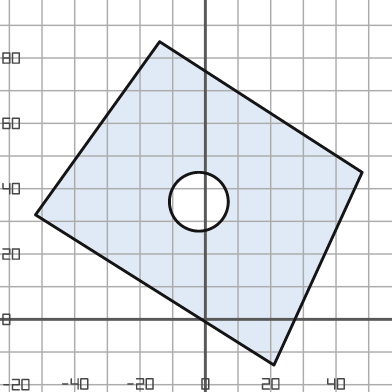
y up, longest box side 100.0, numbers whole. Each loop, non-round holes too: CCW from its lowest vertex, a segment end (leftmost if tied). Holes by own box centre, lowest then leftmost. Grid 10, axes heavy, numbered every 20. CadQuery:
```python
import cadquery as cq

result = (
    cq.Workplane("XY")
    .moveTo(21.0, -14.0)
    .lineTo(48.0, 45.0)
    .lineTo(-14.0, 85.0)
    .lineTo(-52.0, 32.0)
    .close()
    .moveTo(-2.0, 36.0)
    .circle(9.0)
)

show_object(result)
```